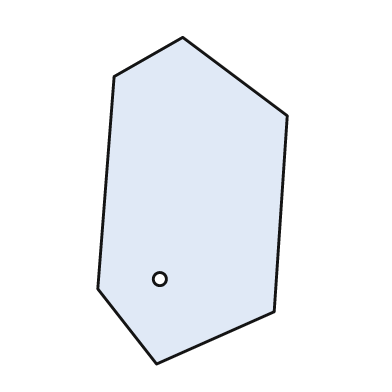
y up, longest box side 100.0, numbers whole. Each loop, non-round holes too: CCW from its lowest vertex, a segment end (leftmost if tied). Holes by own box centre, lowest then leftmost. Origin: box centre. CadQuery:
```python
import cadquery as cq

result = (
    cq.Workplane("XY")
    .moveTo(-11.0, -50.0)
    .lineTo(25.0, -34.0)
    .lineTo(29.0, 26.0)
    .lineTo(-3.0, 50.0)
    .lineTo(-24.0, 38.0)
    .lineTo(-29.0, -27.0)
    .close()
    .moveTo(-10.0, -24.0)
    .circle(2.0)
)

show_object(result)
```